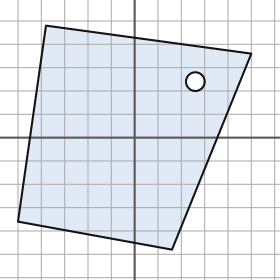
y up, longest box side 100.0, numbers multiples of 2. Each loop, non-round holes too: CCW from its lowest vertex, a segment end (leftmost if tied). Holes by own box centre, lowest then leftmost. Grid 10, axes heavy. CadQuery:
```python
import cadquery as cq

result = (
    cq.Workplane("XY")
    .moveTo(16.0, -48.0)
    .lineTo(50.0, 36.0)
    .lineTo(-38.0, 48.0)
    .lineTo(-50.0, -36.0)
    .close()
    .moveTo(26.0, 24.0)
    .circle(4.0)
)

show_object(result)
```